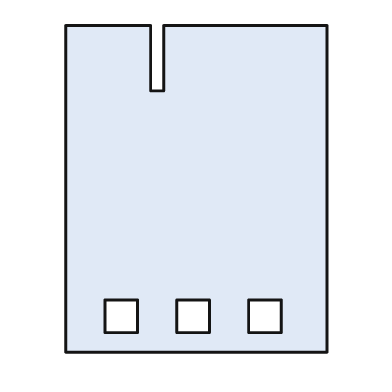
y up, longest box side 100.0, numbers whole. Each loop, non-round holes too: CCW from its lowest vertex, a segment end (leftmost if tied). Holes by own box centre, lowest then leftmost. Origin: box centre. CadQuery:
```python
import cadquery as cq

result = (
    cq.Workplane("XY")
    .moveTo(-40.0, -50.0)
    .lineTo(40.0, -50.0)
    .lineTo(40.0, 50.0)
    .lineTo(-10.0, 50.0)
    .lineTo(-10.0, 30.0)
    .lineTo(-14.0, 30.0)
    .lineTo(-14.0, 50.0)
    .lineTo(-40.0, 50.0)
    .close()
    .moveTo(-28.0, -44.0)
    .lineTo(-18.0, -44.0)
    .lineTo(-18.0, -34.0)
    .lineTo(-28.0, -34.0)
    .close()
    .moveTo(-6.0, -44.0)
    .lineTo(4.0, -44.0)
    .lineTo(4.0, -34.0)
    .lineTo(-6.0, -34.0)
    .close()
    .moveTo(16.0, -44.0)
    .lineTo(26.0, -44.0)
    .lineTo(26.0, -34.0)
    .lineTo(16.0, -34.0)
    .close()
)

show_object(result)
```